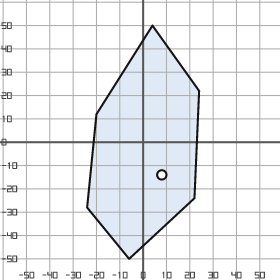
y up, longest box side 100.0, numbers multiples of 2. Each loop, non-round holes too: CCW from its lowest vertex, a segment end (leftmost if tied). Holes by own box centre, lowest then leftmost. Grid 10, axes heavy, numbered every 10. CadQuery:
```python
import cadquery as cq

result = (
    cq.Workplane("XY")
    .moveTo(-6.0, -50.0)
    .lineTo(22.0, -24.0)
    .lineTo(24.0, 22.0)
    .lineTo(4.0, 50.0)
    .lineTo(-20.0, 12.0)
    .lineTo(-24.0, -28.0)
    .close()
    .moveTo(8.0, -14.0)
    .circle(2.0)
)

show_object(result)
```